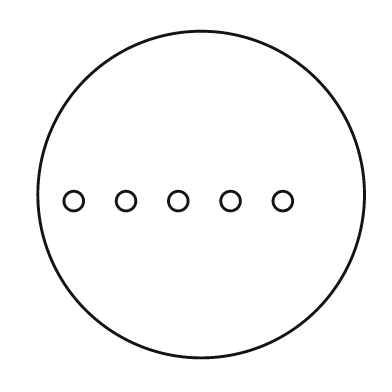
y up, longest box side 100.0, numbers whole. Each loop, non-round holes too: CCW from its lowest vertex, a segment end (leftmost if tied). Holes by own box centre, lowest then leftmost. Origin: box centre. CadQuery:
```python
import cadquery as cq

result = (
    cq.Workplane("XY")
    .moveTo(0.0, 0.0)
    .circle(50.0)
    .moveTo(-39.0, -2.0)
    .circle(3.0)
    .moveTo(-23.0, -2.0)
    .circle(3.0)
    .moveTo(-7.0, -2.0)
    .circle(3.0)
    .moveTo(9.0, -2.0)
    .circle(3.0)
    .moveTo(25.0, -2.0)
    .circle(3.0)
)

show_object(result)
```